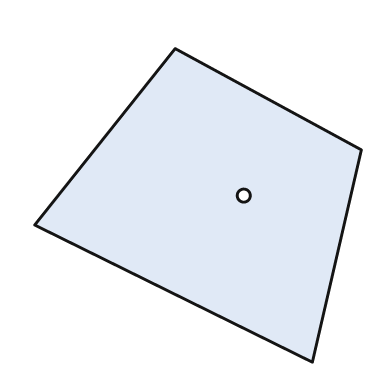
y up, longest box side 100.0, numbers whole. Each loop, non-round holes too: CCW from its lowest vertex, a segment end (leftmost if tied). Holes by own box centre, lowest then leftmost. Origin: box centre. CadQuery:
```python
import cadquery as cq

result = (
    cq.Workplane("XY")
    .moveTo(35.0, -48.0)
    .lineTo(50.0, 17.0)
    .lineTo(-7.0, 48.0)
    .lineTo(-50.0, -6.0)
    .close()
    .moveTo(14.0, 3.0)
    .circle(2.0)
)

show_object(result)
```